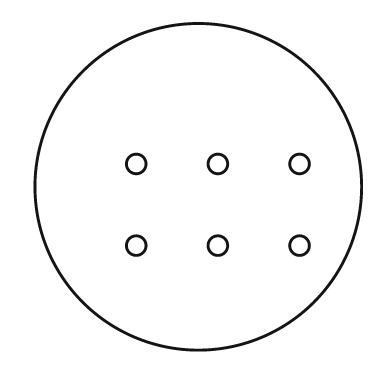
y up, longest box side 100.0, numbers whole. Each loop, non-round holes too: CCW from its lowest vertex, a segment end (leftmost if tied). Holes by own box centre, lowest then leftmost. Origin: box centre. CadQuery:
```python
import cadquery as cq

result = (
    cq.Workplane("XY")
    .moveTo(0.0, 0.0)
    .circle(50.0)
    .moveTo(-19.0, -18.0)
    .circle(3.0)
    .moveTo(6.0, -18.0)
    .circle(3.0)
    .moveTo(31.0, -18.0)
    .circle(3.0)
    .moveTo(-19.0, 7.0)
    .circle(3.0)
    .moveTo(6.0, 7.0)
    .circle(3.0)
    .moveTo(31.0, 7.0)
    .circle(3.0)
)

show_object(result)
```